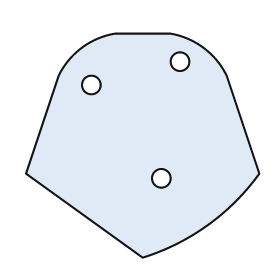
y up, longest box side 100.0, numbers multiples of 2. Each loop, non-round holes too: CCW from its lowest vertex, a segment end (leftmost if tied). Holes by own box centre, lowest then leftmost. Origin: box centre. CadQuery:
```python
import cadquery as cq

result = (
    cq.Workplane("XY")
    .moveTo(0.0, -48.0)
    .threePointArc((28.0, -34.0), (50.0, -12.0))
    .lineTo(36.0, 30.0)
    .threePointArc((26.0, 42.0), (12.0, 48.0))
    .lineTo(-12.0, 48.0)
    .threePointArc((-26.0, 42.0), (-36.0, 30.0))
    .lineTo(-50.0, -12.0)
    .close()
    .moveTo(8.0, -14.0)
    .circle(4.0)
    .moveTo(-22.0, 26.0)
    .circle(4.0)
    .moveTo(16.0, 36.0)
    .circle(4.0)
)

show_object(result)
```